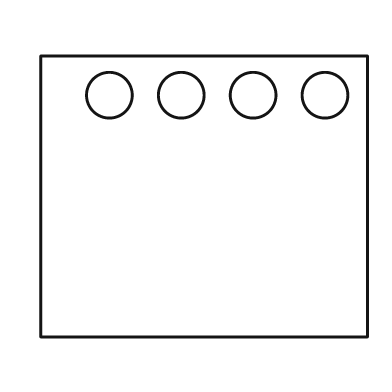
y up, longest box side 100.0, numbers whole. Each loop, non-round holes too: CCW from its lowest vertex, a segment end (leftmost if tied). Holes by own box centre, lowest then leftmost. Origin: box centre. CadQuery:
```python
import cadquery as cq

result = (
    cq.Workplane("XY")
    .moveTo(-50.0, -43.0)
    .lineTo(50.0, -43.0)
    .lineTo(50.0, 43.0)
    .lineTo(-50.0, 43.0)
    .close()
    .moveTo(-29.0, 31.0)
    .circle(7.0)
    .moveTo(-7.0, 31.0)
    .circle(7.0)
    .moveTo(15.0, 31.0)
    .circle(7.0)
    .moveTo(37.0, 31.0)
    .circle(7.0)
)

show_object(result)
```